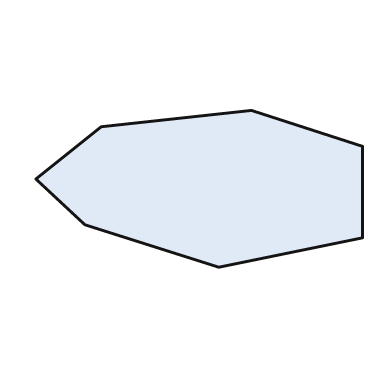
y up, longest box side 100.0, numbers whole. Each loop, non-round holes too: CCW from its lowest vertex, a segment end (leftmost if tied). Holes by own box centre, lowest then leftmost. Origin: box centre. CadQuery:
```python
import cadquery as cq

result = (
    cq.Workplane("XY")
    .moveTo(6.0, -24.0)
    .lineTo(50.0, -15.0)
    .lineTo(50.0, 13.0)
    .lineTo(16.0, 24.0)
    .lineTo(-30.0, 19.0)
    .lineTo(-50.0, 3.0)
    .lineTo(-35.0, -11.0)
    .close()
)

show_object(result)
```